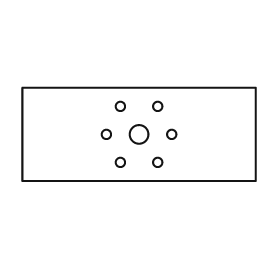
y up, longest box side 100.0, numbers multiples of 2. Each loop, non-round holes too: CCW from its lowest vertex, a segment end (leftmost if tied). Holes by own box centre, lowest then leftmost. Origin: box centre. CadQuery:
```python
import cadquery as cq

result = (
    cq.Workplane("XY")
    .moveTo(-50.0, -20.0)
    .lineTo(50.0, -20.0)
    .lineTo(50.0, 20.0)
    .lineTo(-50.0, 20.0)
    .close()
    .moveTo(-8.0, -12.0)
    .circle(2.0)
    .moveTo(8.0, -12.0)
    .circle(2.0)
    .moveTo(-14.0, 0.0)
    .circle(2.0)
    .moveTo(0.0, 0.0)
    .circle(4.0)
    .moveTo(14.0, 0.0)
    .circle(2.0)
    .moveTo(-8.0, 12.0)
    .circle(2.0)
    .moveTo(8.0, 12.0)
    .circle(2.0)
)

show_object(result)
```